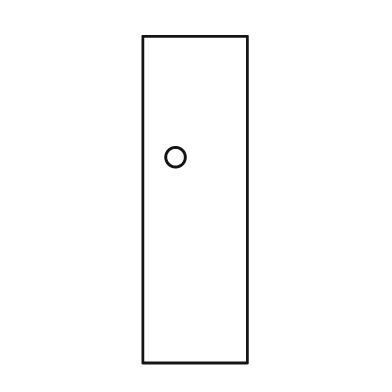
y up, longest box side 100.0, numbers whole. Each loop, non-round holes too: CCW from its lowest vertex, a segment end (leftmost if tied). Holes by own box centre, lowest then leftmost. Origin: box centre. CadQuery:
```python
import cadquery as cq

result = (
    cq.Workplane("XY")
    .moveTo(-16.0, -50.0)
    .lineTo(16.0, -50.0)
    .lineTo(16.0, 50.0)
    .lineTo(-16.0, 50.0)
    .close()
    .moveTo(-6.0, 13.0)
    .circle(3.0)
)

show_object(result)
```